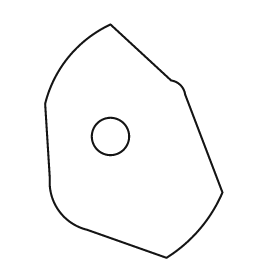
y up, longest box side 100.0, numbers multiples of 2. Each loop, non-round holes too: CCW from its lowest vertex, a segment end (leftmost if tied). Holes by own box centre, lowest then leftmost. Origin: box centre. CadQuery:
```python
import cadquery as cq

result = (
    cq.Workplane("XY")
    .moveTo(14.0, -50.0)
    .threePointArc((28.0, -38.0), (38.0, -22.0))
    .lineTo(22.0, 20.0)
    .threePointArc((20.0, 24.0), (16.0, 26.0))
    .lineTo(-10.0, 50.0)
    .threePointArc((-28.0, 36.0), (-38.0, 16.0))
    .lineTo(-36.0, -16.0)
    .threePointArc((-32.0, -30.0), (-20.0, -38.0))
    .close()
    .moveTo(-10.0, 2.0)
    .circle(8.0)
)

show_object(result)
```